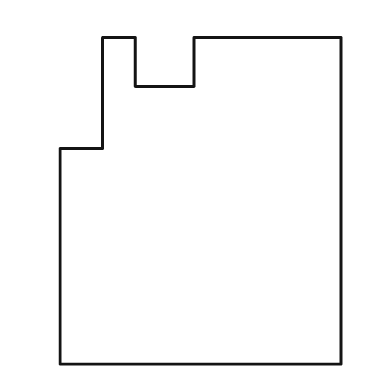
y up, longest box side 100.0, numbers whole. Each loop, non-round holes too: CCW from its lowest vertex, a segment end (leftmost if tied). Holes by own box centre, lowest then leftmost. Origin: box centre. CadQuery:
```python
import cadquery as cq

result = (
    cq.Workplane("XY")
    .moveTo(-43.0, -50.0)
    .lineTo(43.0, -50.0)
    .lineTo(43.0, 50.0)
    .lineTo(-2.0, 50.0)
    .lineTo(-2.0, 35.0)
    .lineTo(-20.0, 35.0)
    .lineTo(-20.0, 50.0)
    .lineTo(-30.0, 50.0)
    .lineTo(-30.0, 16.0)
    .lineTo(-43.0, 16.0)
    .close()
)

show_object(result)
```